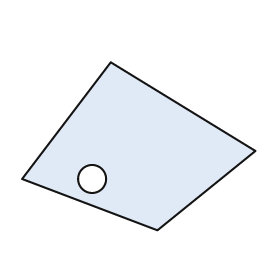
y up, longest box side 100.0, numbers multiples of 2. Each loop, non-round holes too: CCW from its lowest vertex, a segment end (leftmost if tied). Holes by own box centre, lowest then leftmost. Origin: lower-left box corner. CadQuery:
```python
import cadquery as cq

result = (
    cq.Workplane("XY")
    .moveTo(58.0, 0.0)
    .lineTo(100.0, 34.0)
    .lineTo(38.0, 72.0)
    .lineTo(0.0, 22.0)
    .close()
    .moveTo(30.0, 22.0)
    .circle(6.0)
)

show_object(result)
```